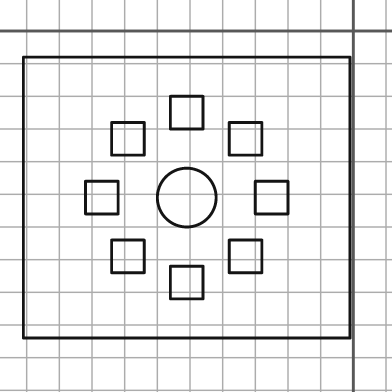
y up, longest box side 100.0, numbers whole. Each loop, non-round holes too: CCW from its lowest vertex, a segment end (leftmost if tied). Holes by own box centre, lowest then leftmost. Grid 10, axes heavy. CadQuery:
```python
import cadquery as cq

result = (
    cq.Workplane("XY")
    .moveTo(-101.0, -94.0)
    .lineTo(-1.0, -94.0)
    .lineTo(-1.0, -8.0)
    .lineTo(-101.0, -8.0)
    .close()
    .moveTo(-56.0, -82.0)
    .lineTo(-46.0, -82.0)
    .lineTo(-46.0, -72.0)
    .lineTo(-56.0, -72.0)
    .close()
    .moveTo(-74.0, -74.0)
    .lineTo(-64.0, -74.0)
    .lineTo(-64.0, -64.0)
    .lineTo(-74.0, -64.0)
    .close()
    .moveTo(-38.0, -74.0)
    .lineTo(-28.0, -74.0)
    .lineTo(-28.0, -64.0)
    .lineTo(-38.0, -64.0)
    .close()
    .moveTo(-82.0, -56.0)
    .lineTo(-72.0, -56.0)
    .lineTo(-72.0, -46.0)
    .lineTo(-82.0, -46.0)
    .close()
    .moveTo(-51.0, -51.0)
    .circle(9.0)
    .moveTo(-30.0, -56.0)
    .lineTo(-20.0, -56.0)
    .lineTo(-20.0, -46.0)
    .lineTo(-30.0, -46.0)
    .close()
    .moveTo(-74.0, -38.0)
    .lineTo(-64.0, -38.0)
    .lineTo(-64.0, -28.0)
    .lineTo(-74.0, -28.0)
    .close()
    .moveTo(-38.0, -38.0)
    .lineTo(-28.0, -38.0)
    .lineTo(-28.0, -28.0)
    .lineTo(-38.0, -28.0)
    .close()
    .moveTo(-56.0, -30.0)
    .lineTo(-46.0, -30.0)
    .lineTo(-46.0, -20.0)
    .lineTo(-56.0, -20.0)
    .close()
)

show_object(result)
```